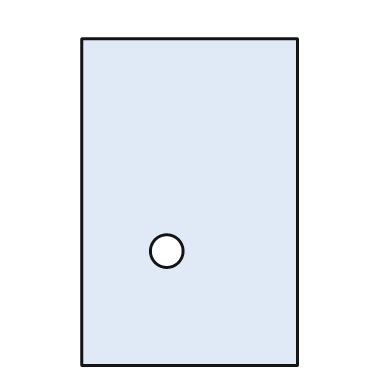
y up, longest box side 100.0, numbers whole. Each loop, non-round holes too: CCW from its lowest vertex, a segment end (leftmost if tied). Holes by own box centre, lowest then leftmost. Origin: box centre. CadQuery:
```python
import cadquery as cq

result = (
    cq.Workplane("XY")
    .moveTo(-33.0, -50.0)
    .lineTo(33.0, -50.0)
    .lineTo(33.0, 50.0)
    .lineTo(-33.0, 50.0)
    .close()
    .moveTo(-7.0, -15.0)
    .circle(5.0)
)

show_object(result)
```